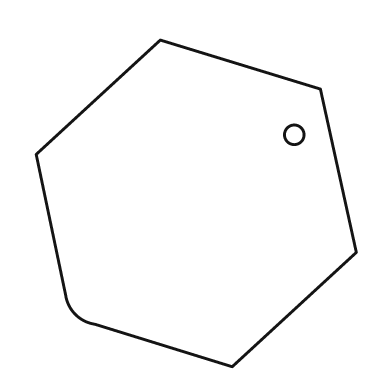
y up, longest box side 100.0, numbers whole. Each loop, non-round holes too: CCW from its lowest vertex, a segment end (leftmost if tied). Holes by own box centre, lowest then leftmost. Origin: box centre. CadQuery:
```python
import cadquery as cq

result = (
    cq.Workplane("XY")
    .moveTo(11.0, -50.0)
    .lineTo(49.0, -15.0)
    .lineTo(38.0, 35.0)
    .lineTo(-11.0, 50.0)
    .lineTo(-49.0, 15.0)
    .lineTo(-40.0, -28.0)
    .threePointArc((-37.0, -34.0), (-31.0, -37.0))
    .close()
    .moveTo(30.0, 21.0)
    .circle(3.0)
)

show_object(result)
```